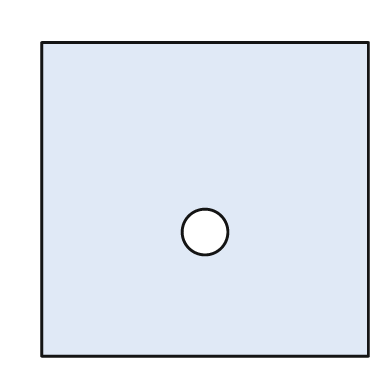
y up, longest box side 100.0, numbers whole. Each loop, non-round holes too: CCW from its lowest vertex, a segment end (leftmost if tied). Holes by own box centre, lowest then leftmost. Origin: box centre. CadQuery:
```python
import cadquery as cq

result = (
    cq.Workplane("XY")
    .moveTo(-50.0, -48.0)
    .lineTo(50.0, -48.0)
    .lineTo(50.0, 48.0)
    .lineTo(-50.0, 48.0)
    .close()
    .moveTo(0.0, -10.0)
    .circle(7.0)
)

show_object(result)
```